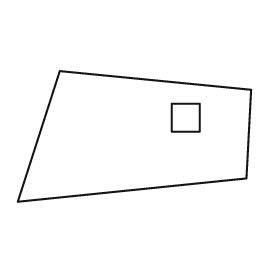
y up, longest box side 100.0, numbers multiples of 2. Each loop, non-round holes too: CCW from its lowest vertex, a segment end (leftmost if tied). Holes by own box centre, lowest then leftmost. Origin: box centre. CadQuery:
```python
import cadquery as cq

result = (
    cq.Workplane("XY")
    .moveTo(-50.0, -28.0)
    .lineTo(48.0, -18.0)
    .lineTo(50.0, 20.0)
    .lineTo(-32.0, 28.0)
    .close()
    .moveTo(16.0, 2.0)
    .lineTo(28.0, 2.0)
    .lineTo(28.0, 14.0)
    .lineTo(16.0, 14.0)
    .close()
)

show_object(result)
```